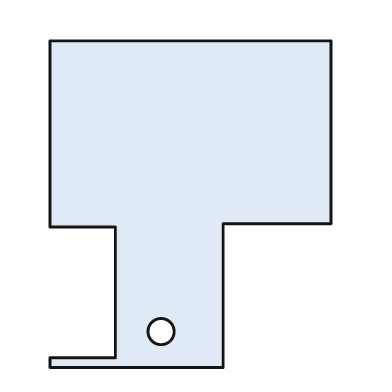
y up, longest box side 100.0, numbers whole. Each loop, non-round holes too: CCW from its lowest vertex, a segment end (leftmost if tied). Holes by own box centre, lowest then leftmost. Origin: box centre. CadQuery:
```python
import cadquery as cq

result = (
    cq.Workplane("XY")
    .moveTo(-43.0, -50.0)
    .lineTo(10.0, -50.0)
    .lineTo(10.0, -6.0)
    .lineTo(43.0, -6.0)
    .lineTo(43.0, 50.0)
    .lineTo(-43.0, 50.0)
    .lineTo(-43.0, -7.0)
    .lineTo(-23.0, -7.0)
    .lineTo(-23.0, -47.0)
    .lineTo(-43.0, -47.0)
    .close()
    .moveTo(-9.0, -39.0)
    .circle(4.0)
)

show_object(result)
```